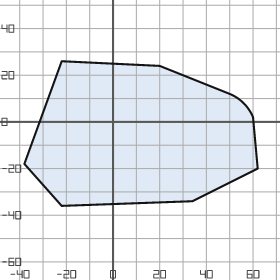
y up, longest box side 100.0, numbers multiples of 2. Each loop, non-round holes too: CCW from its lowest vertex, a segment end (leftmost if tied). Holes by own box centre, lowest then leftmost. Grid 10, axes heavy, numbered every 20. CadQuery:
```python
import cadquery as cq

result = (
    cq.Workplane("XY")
    .moveTo(-22.0, -36.0)
    .lineTo(34.0, -34.0)
    .lineTo(62.0, -20.0)
    .lineTo(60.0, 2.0)
    .threePointArc((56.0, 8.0), (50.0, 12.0))
    .lineTo(20.0, 24.0)
    .lineTo(-22.0, 26.0)
    .lineTo(-38.0, -18.0)
    .close()
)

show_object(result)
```